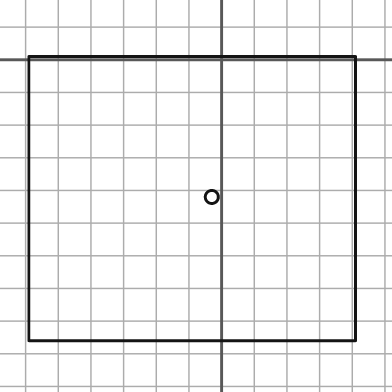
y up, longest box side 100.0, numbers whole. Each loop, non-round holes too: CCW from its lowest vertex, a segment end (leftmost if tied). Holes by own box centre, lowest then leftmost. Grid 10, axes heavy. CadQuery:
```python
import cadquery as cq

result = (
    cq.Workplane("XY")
    .moveTo(-59.0, -86.0)
    .lineTo(41.0, -86.0)
    .lineTo(41.0, 1.0)
    .lineTo(-59.0, 1.0)
    .close()
    .moveTo(-3.0, -42.0)
    .circle(2.0)
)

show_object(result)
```